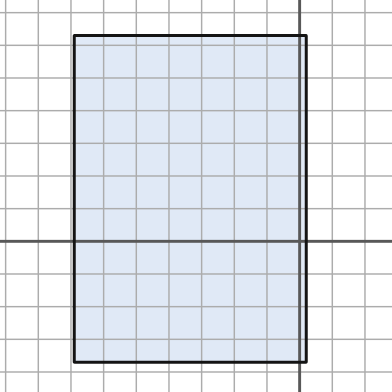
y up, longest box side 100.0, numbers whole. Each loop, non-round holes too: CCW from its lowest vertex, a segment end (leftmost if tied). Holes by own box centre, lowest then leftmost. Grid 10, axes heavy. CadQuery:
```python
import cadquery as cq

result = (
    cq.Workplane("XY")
    .moveTo(-69.0, -37.0)
    .lineTo(2.0, -37.0)
    .lineTo(2.0, 63.0)
    .lineTo(-69.0, 63.0)
    .close()
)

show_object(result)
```